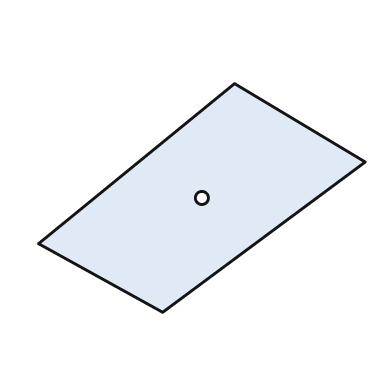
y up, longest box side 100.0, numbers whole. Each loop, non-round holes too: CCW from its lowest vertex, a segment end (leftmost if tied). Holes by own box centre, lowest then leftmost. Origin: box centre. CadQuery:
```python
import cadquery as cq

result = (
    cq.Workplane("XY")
    .moveTo(-12.0, -35.0)
    .lineTo(50.0, 11.0)
    .lineTo(10.0, 35.0)
    .lineTo(-50.0, -14.0)
    .close()
    .moveTo(0.0, 0.0)
    .circle(2.0)
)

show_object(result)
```